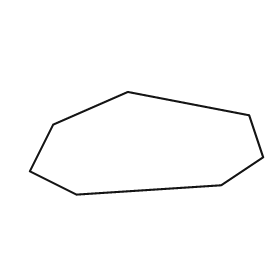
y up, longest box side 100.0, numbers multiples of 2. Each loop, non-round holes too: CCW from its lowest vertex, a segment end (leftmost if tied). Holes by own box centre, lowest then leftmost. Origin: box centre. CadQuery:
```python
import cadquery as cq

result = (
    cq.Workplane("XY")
    .moveTo(-30.0, -22.0)
    .lineTo(32.0, -18.0)
    .lineTo(50.0, -6.0)
    .lineTo(44.0, 12.0)
    .lineTo(-8.0, 22.0)
    .lineTo(-40.0, 8.0)
    .lineTo(-50.0, -12.0)
    .close()
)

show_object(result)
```